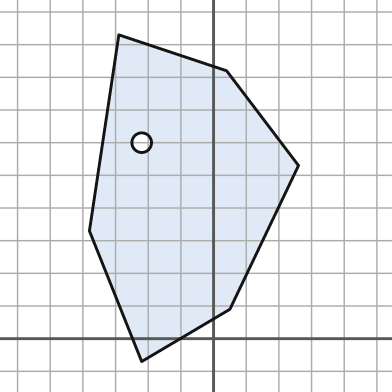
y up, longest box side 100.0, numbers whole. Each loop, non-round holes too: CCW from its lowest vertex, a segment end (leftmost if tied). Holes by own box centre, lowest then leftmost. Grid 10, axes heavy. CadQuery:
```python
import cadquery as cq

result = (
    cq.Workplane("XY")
    .moveTo(-22.0, -7.0)
    .lineTo(5.0, 9.0)
    .lineTo(26.0, 53.0)
    .lineTo(4.0, 82.0)
    .lineTo(-29.0, 93.0)
    .lineTo(-38.0, 33.0)
    .close()
    .moveTo(-22.0, 60.0)
    .circle(3.0)
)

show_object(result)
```